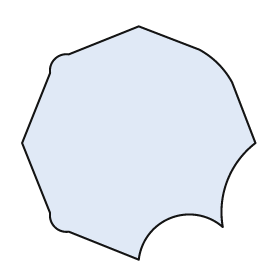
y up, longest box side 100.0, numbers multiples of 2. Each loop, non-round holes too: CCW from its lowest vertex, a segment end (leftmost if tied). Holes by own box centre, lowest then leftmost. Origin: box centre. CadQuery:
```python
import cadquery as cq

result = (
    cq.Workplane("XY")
    .moveTo(0.0, -50.0)
    .threePointArc((14.0, -32.0), (36.0, -36.0))
    .threePointArc((38.0, -16.0), (50.0, 0.0))
    .lineTo(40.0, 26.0)
    .threePointArc((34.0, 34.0), (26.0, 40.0))
    .lineTo(0.0, 50.0)
    .lineTo(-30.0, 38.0)
    .threePointArc((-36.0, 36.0), (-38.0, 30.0))
    .lineTo(-50.0, 0.0)
    .lineTo(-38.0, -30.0)
    .threePointArc((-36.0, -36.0), (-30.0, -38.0))
    .close()
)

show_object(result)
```